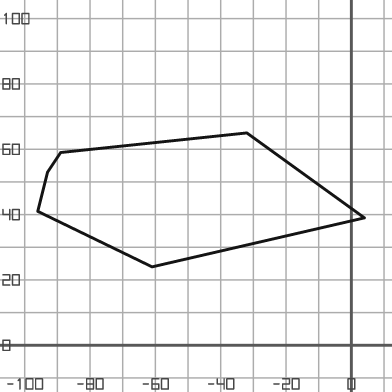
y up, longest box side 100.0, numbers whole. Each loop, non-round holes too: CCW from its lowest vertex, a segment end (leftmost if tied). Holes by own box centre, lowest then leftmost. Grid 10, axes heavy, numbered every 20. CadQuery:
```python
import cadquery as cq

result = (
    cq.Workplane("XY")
    .moveTo(-61.0, 24.0)
    .lineTo(4.0, 39.0)
    .lineTo(-32.0, 65.0)
    .lineTo(-89.0, 59.0)
    .lineTo(-93.0, 53.0)
    .lineTo(-96.0, 41.0)
    .close()
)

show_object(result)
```